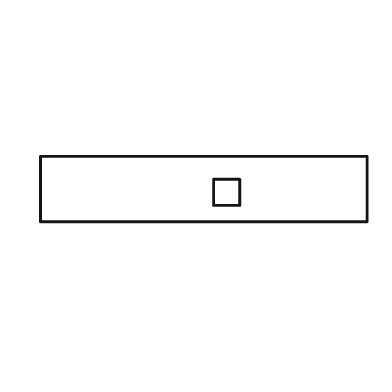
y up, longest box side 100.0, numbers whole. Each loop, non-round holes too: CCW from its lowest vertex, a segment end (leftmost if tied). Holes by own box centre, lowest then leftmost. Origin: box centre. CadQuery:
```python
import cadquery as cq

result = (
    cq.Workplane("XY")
    .moveTo(-50.0, -10.0)
    .lineTo(50.0, -10.0)
    .lineTo(50.0, 10.0)
    .lineTo(-50.0, 10.0)
    .close()
    .moveTo(3.0, -5.0)
    .lineTo(11.0, -5.0)
    .lineTo(11.0, 3.0)
    .lineTo(3.0, 3.0)
    .close()
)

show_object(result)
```